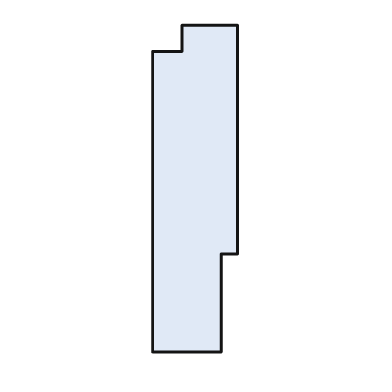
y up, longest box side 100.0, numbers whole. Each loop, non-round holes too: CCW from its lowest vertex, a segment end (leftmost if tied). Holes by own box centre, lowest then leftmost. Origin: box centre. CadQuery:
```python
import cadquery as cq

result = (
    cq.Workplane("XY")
    .moveTo(-13.0, -50.0)
    .lineTo(8.0, -50.0)
    .lineTo(8.0, -20.0)
    .lineTo(13.0, -20.0)
    .lineTo(13.0, 50.0)
    .lineTo(-4.0, 50.0)
    .lineTo(-4.0, 42.0)
    .lineTo(-13.0, 42.0)
    .close()
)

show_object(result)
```